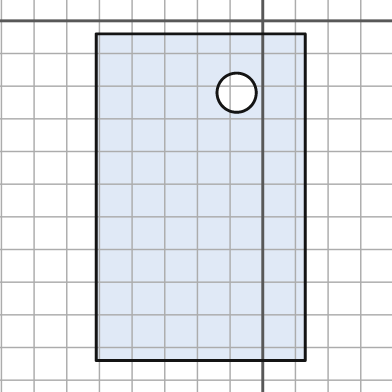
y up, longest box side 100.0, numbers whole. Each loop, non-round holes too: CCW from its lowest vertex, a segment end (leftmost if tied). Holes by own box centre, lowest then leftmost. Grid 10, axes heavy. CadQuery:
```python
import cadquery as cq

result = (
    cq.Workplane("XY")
    .moveTo(-51.0, -104.0)
    .lineTo(13.0, -104.0)
    .lineTo(13.0, -4.0)
    .lineTo(-51.0, -4.0)
    .close()
    .moveTo(-8.0, -22.0)
    .circle(6.0)
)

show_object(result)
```